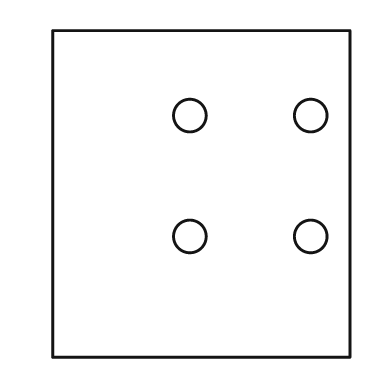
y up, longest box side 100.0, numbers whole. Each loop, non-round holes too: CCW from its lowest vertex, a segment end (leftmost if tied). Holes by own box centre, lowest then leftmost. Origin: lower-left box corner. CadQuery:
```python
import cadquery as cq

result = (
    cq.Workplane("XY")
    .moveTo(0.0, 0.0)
    .lineTo(91.0, 0.0)
    .lineTo(91.0, 100.0)
    .lineTo(0.0, 100.0)
    .close()
    .moveTo(42.0, 37.0)
    .circle(5.0)
    .moveTo(79.0, 37.0)
    .circle(5.0)
    .moveTo(42.0, 74.0)
    .circle(5.0)
    .moveTo(79.0, 74.0)
    .circle(5.0)
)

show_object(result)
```